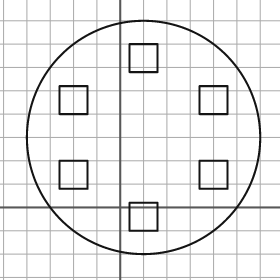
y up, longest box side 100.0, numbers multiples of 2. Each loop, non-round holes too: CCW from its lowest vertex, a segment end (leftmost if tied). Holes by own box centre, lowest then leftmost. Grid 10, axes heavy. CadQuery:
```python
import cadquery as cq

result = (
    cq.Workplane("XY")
    .moveTo(10.0, 30.0)
    .circle(50.0)
    .moveTo(4.0, -10.0)
    .lineTo(16.0, -10.0)
    .lineTo(16.0, 2.0)
    .lineTo(4.0, 2.0)
    .close()
    .moveTo(-26.0, 8.0)
    .lineTo(-14.0, 8.0)
    .lineTo(-14.0, 20.0)
    .lineTo(-26.0, 20.0)
    .close()
    .moveTo(34.0, 8.0)
    .lineTo(46.0, 8.0)
    .lineTo(46.0, 20.0)
    .lineTo(34.0, 20.0)
    .close()
    .moveTo(-26.0, 40.0)
    .lineTo(-14.0, 40.0)
    .lineTo(-14.0, 52.0)
    .lineTo(-26.0, 52.0)
    .close()
    .moveTo(34.0, 40.0)
    .lineTo(46.0, 40.0)
    .lineTo(46.0, 52.0)
    .lineTo(34.0, 52.0)
    .close()
    .moveTo(4.0, 58.0)
    .lineTo(16.0, 58.0)
    .lineTo(16.0, 70.0)
    .lineTo(4.0, 70.0)
    .close()
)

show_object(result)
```